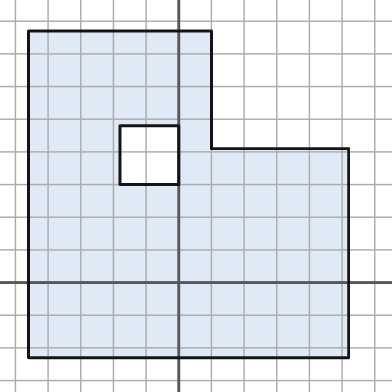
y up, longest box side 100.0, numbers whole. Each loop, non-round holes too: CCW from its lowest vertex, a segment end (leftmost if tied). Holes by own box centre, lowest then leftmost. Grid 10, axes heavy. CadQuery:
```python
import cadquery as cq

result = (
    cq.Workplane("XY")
    .moveTo(-46.0, -23.0)
    .lineTo(52.0, -23.0)
    .lineTo(52.0, 41.0)
    .lineTo(10.0, 41.0)
    .lineTo(10.0, 77.0)
    .lineTo(-46.0, 77.0)
    .close()
    .moveTo(-18.0, 30.0)
    .lineTo(0.0, 30.0)
    .lineTo(0.0, 48.0)
    .lineTo(-18.0, 48.0)
    .close()
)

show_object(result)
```